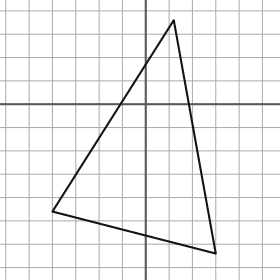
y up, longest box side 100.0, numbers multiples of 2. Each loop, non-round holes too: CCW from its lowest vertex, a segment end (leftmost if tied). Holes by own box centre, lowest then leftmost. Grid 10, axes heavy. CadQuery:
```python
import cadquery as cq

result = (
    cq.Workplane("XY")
    .moveTo(30.0, -64.0)
    .lineTo(12.0, 36.0)
    .lineTo(-40.0, -46.0)
    .close()
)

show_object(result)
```